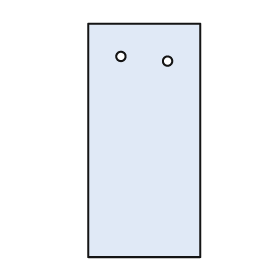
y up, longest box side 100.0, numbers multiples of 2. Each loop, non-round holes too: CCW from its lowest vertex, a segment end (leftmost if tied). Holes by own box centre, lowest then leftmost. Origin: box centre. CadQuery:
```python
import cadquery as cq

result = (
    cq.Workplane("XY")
    .moveTo(-24.0, -50.0)
    .lineTo(24.0, -50.0)
    .lineTo(24.0, 50.0)
    .lineTo(-24.0, 50.0)
    .close()
    .moveTo(10.0, 34.0)
    .circle(2.0)
    .moveTo(-10.0, 36.0)
    .circle(2.0)
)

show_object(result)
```